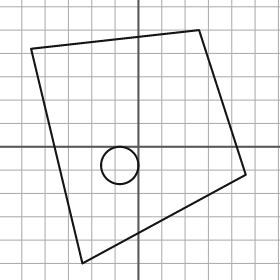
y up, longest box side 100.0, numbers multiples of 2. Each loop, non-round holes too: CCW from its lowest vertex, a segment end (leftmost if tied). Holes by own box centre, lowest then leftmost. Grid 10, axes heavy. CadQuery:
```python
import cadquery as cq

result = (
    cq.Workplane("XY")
    .moveTo(-24.0, -50.0)
    .lineTo(46.0, -12.0)
    .lineTo(26.0, 50.0)
    .lineTo(-46.0, 42.0)
    .close()
    .moveTo(-8.0, -8.0)
    .circle(8.0)
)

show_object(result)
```